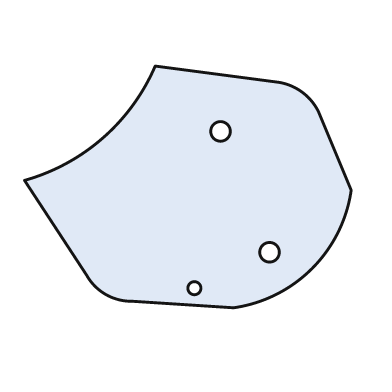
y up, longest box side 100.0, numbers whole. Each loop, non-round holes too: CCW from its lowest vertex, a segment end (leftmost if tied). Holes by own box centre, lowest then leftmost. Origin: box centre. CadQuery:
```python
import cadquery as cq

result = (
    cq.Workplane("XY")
    .moveTo(14.0, -37.0)
    .threePointArc((38.0, -25.0), (50.0, -1.0))
    .lineTo(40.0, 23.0)
    .threePointArc((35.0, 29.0), (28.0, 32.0))
    .lineTo(-10.0, 37.0)
    .threePointArc((-26.0, 15.0), (-50.0, 2.0))
    .lineTo(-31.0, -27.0)
    .threePointArc((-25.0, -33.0), (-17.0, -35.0))
    .close()
    .moveTo(2.0, -31.0)
    .circle(2.0)
    .moveTo(25.0, -20.0)
    .circle(3.0)
    .moveTo(10.0, 17.0)
    .circle(3.0)
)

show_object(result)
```